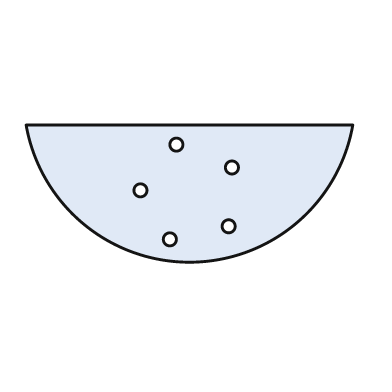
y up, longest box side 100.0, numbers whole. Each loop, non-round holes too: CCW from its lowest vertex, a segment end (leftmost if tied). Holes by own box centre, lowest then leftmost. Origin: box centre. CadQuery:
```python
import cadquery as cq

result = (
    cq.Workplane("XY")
    .moveTo(-50.0, 21.0)
    .threePointArc((0.0, -21.0), (50.0, 21.0))
    .close()
    .moveTo(-6.0, -14.0)
    .circle(2.0)
    .moveTo(12.0, -10.0)
    .circle(2.0)
    .moveTo(-15.0, 1.0)
    .circle(2.0)
    .moveTo(13.0, 8.0)
    .circle(2.0)
    .moveTo(-4.0, 15.0)
    .circle(2.0)
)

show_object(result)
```